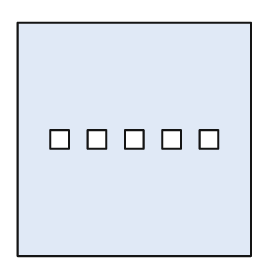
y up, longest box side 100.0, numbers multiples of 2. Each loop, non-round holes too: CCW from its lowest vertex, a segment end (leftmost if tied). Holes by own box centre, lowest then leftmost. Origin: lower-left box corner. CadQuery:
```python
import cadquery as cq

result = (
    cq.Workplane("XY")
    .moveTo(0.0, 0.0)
    .lineTo(100.0, 0.0)
    .lineTo(100.0, 100.0)
    .lineTo(0.0, 100.0)
    .close()
    .moveTo(14.0, 46.0)
    .lineTo(22.0, 46.0)
    .lineTo(22.0, 54.0)
    .lineTo(14.0, 54.0)
    .close()
    .moveTo(30.0, 46.0)
    .lineTo(38.0, 46.0)
    .lineTo(38.0, 54.0)
    .lineTo(30.0, 54.0)
    .close()
    .moveTo(46.0, 46.0)
    .lineTo(54.0, 46.0)
    .lineTo(54.0, 54.0)
    .lineTo(46.0, 54.0)
    .close()
    .moveTo(62.0, 46.0)
    .lineTo(70.0, 46.0)
    .lineTo(70.0, 54.0)
    .lineTo(62.0, 54.0)
    .close()
    .moveTo(78.0, 46.0)
    .lineTo(86.0, 46.0)
    .lineTo(86.0, 54.0)
    .lineTo(78.0, 54.0)
    .close()
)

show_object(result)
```